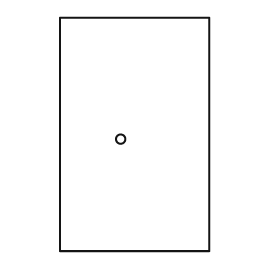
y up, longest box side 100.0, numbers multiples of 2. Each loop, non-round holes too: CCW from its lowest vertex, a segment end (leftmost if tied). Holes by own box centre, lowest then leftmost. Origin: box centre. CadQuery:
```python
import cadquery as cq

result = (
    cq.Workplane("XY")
    .moveTo(-32.0, -50.0)
    .lineTo(32.0, -50.0)
    .lineTo(32.0, 50.0)
    .lineTo(-32.0, 50.0)
    .close()
    .moveTo(-6.0, -2.0)
    .circle(2.0)
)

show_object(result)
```